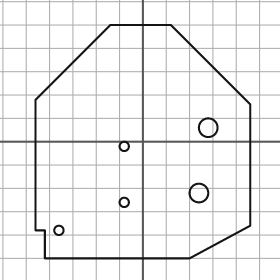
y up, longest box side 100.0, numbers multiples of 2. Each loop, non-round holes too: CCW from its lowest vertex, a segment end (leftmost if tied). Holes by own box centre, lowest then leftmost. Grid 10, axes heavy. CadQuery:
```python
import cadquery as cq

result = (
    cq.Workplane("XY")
    .moveTo(-42.0, -50.0)
    .lineTo(20.0, -50.0)
    .lineTo(46.0, -36.0)
    .lineTo(46.0, 16.0)
    .lineTo(12.0, 50.0)
    .lineTo(-14.0, 50.0)
    .lineTo(-46.0, 18.0)
    .lineTo(-46.0, -38.0)
    .lineTo(-42.0, -38.0)
    .close()
    .moveTo(-36.0, -38.0)
    .circle(2.0)
    .moveTo(-8.0, -26.0)
    .circle(2.0)
    .moveTo(24.0, -22.0)
    .circle(4.0)
    .moveTo(-8.0, -2.0)
    .circle(2.0)
    .moveTo(28.0, 6.0)
    .circle(4.0)
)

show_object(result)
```